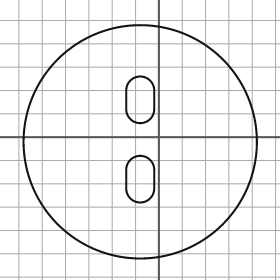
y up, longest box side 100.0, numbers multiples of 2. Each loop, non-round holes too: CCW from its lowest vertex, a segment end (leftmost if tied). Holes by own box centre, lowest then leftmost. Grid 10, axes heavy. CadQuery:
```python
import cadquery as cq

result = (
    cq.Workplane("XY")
    .moveTo(-8.0, -2.0)
    .circle(50.0)
    .moveTo(-14.0, -22.0)
    .threePointArc((-8.0, -28.0), (-2.0, -22.0))
    .lineTo(-2.0, -14.0)
    .threePointArc((-8.0, -8.0), (-14.0, -14.0))
    .close()
    .moveTo(-14.0, 12.0)
    .threePointArc((-8.0, 6.0), (-2.0, 12.0))
    .lineTo(-2.0, 20.0)
    .threePointArc((-8.0, 26.0), (-14.0, 20.0))
    .close()
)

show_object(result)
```